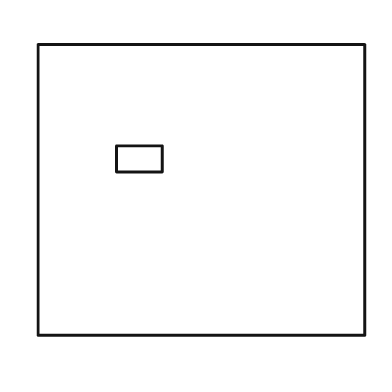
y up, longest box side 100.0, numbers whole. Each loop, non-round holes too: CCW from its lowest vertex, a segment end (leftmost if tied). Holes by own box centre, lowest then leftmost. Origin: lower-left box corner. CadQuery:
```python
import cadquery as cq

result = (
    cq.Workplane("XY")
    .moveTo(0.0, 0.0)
    .lineTo(100.0, 0.0)
    .lineTo(100.0, 89.0)
    .lineTo(0.0, 89.0)
    .close()
    .moveTo(24.0, 50.0)
    .lineTo(38.0, 50.0)
    .lineTo(38.0, 58.0)
    .lineTo(24.0, 58.0)
    .close()
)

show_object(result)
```